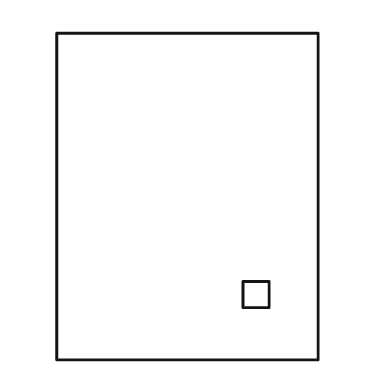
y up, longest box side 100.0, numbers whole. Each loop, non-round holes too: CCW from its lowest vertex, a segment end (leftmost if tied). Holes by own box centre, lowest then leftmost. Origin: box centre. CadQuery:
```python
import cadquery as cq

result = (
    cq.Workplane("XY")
    .moveTo(-40.0, -50.0)
    .lineTo(40.0, -50.0)
    .lineTo(40.0, 50.0)
    .lineTo(-40.0, 50.0)
    .close()
    .moveTo(17.0, -34.0)
    .lineTo(25.0, -34.0)
    .lineTo(25.0, -26.0)
    .lineTo(17.0, -26.0)
    .close()
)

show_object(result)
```